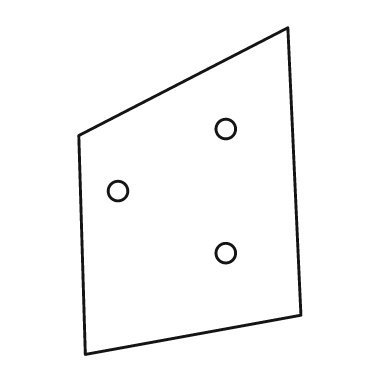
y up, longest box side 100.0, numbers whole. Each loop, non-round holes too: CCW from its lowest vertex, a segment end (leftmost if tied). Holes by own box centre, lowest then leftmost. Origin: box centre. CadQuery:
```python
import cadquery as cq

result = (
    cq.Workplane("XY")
    .moveTo(-32.0, -50.0)
    .lineTo(34.0, -38.0)
    .lineTo(30.0, 50.0)
    .lineTo(-34.0, 17.0)
    .close()
    .moveTo(11.0, -19.0)
    .circle(3.0)
    .moveTo(-22.0, 0.0)
    .circle(3.0)
    .moveTo(11.0, 19.0)
    .circle(3.0)
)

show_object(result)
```